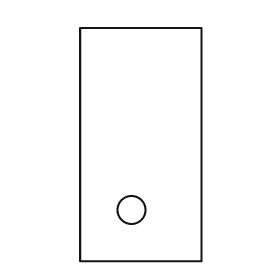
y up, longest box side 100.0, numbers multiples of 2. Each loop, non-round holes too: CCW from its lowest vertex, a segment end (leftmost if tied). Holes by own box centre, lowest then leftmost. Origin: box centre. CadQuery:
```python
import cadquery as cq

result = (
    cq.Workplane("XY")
    .moveTo(-26.0, -50.0)
    .lineTo(26.0, -50.0)
    .lineTo(26.0, 50.0)
    .lineTo(-26.0, 50.0)
    .close()
    .moveTo(-4.0, -28.0)
    .circle(6.0)
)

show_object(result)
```